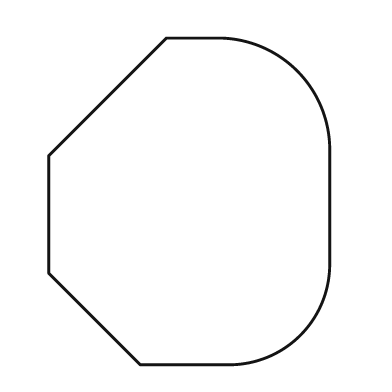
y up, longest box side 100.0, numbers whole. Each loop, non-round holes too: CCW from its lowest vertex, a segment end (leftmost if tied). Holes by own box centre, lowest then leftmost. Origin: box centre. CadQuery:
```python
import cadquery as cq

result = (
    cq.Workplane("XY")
    .moveTo(-15.0, -50.0)
    .lineTo(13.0, -50.0)
    .threePointArc((34.0, -41.0), (43.0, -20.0))
    .lineTo(43.0, 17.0)
    .threePointArc((33.0, 40.0), (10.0, 50.0))
    .lineTo(-7.0, 50.0)
    .lineTo(-43.0, 14.0)
    .lineTo(-43.0, -22.0)
    .close()
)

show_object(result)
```